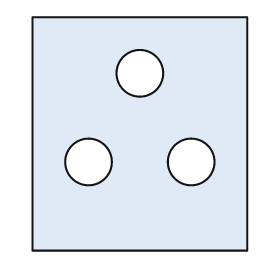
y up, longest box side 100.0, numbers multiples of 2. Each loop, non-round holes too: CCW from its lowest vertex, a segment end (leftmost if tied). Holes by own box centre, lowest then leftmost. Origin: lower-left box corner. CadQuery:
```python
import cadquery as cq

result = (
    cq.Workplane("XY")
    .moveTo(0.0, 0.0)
    .lineTo(92.0, 0.0)
    .lineTo(92.0, 100.0)
    .lineTo(0.0, 100.0)
    .close()
    .moveTo(24.0, 38.0)
    .circle(10.0)
    .moveTo(68.0, 38.0)
    .circle(10.0)
    .moveTo(46.0, 76.0)
    .circle(10.0)
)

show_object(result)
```